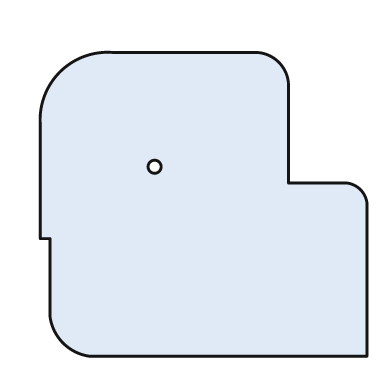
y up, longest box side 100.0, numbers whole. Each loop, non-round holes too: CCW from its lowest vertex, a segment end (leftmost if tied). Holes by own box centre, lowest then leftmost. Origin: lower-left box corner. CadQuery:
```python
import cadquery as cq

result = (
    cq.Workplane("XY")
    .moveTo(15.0, 0.0)
    .lineTo(100.0, 0.0)
    .lineTo(100.0, 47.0)
    .threePointArc((98.0, 51.0), (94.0, 53.0))
    .lineTo(76.0, 53.0)
    .lineTo(76.0, 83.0)
    .threePointArc((73.0, 90.0), (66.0, 93.0))
    .lineTo(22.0, 93.0)
    .threePointArc((6.0, 87.0), (0.0, 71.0))
    .lineTo(0.0, 36.0)
    .lineTo(3.0, 36.0)
    .lineTo(3.0, 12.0)
    .threePointArc((7.0, 4.0), (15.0, 0.0))
    .close()
    .moveTo(35.0, 58.0)
    .circle(2.0)
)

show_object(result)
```